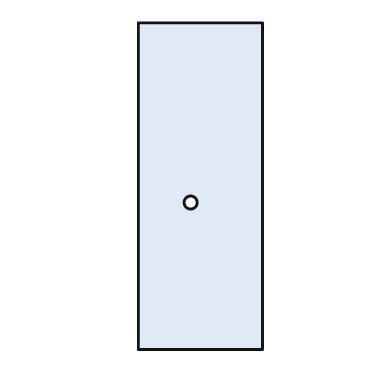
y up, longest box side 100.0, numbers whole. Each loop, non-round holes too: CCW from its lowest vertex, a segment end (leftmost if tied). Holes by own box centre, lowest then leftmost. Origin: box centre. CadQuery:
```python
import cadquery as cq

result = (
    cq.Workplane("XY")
    .moveTo(-19.0, -50.0)
    .lineTo(19.0, -50.0)
    .lineTo(19.0, 50.0)
    .lineTo(-19.0, 50.0)
    .close()
    .moveTo(-3.0, -5.0)
    .circle(2.0)
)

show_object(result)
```